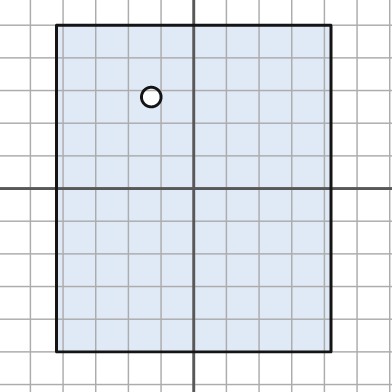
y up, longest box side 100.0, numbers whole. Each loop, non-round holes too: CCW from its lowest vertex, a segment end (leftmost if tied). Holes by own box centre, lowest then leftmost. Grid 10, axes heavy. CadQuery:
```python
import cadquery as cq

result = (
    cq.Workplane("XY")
    .moveTo(-42.0, -50.0)
    .lineTo(42.0, -50.0)
    .lineTo(42.0, 50.0)
    .lineTo(-42.0, 50.0)
    .close()
    .moveTo(-13.0, 28.0)
    .circle(3.0)
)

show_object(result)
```